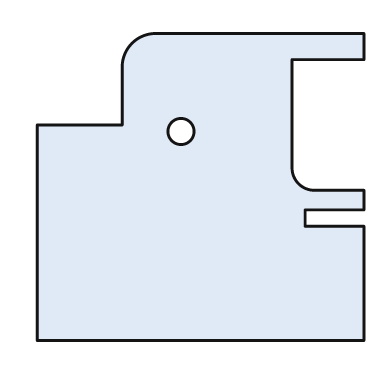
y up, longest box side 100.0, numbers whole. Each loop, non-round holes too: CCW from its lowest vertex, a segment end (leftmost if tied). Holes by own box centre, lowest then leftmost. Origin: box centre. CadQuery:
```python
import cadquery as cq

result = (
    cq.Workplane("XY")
    .moveTo(-50.0, -47.0)
    .lineTo(50.0, -47.0)
    .lineTo(50.0, -12.0)
    .lineTo(32.0, -12.0)
    .lineTo(32.0, -7.0)
    .lineTo(50.0, -7.0)
    .lineTo(50.0, -1.0)
    .lineTo(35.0, -1.0)
    .threePointArc((30.0, 1.0), (28.0, 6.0))
    .lineTo(28.0, 39.0)
    .lineTo(50.0, 39.0)
    .lineTo(50.0, 47.0)
    .lineTo(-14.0, 47.0)
    .threePointArc((-21.0, 44.0), (-24.0, 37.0))
    .lineTo(-24.0, 19.0)
    .lineTo(-50.0, 19.0)
    .close()
    .moveTo(-6.0, 17.0)
    .circle(4.0)
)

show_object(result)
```